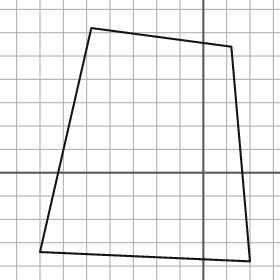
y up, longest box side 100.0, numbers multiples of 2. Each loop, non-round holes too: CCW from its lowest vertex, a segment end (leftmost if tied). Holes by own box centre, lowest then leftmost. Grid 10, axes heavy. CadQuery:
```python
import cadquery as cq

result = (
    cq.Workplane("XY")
    .moveTo(20.0, -38.0)
    .lineTo(12.0, 54.0)
    .lineTo(-48.0, 62.0)
    .lineTo(-70.0, -34.0)
    .close()
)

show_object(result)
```